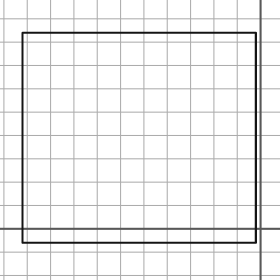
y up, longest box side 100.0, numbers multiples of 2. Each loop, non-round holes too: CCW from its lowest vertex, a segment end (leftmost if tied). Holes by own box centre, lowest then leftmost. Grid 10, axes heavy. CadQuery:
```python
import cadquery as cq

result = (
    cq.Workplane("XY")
    .moveTo(-102.0, -6.0)
    .lineTo(-2.0, -6.0)
    .lineTo(-2.0, 84.0)
    .lineTo(-102.0, 84.0)
    .close()
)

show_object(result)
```